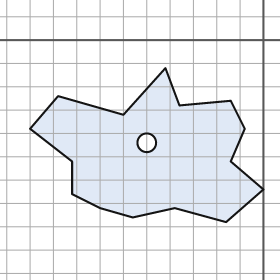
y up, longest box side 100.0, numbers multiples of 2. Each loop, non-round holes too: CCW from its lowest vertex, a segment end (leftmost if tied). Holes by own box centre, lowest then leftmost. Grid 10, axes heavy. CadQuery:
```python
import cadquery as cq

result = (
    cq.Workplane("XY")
    .moveTo(-16.0, -78.0)
    .lineTo(0.0, -64.0)
    .lineTo(-14.0, -52.0)
    .lineTo(-8.0, -38.0)
    .lineTo(-14.0, -26.0)
    .lineTo(-36.0, -28.0)
    .lineTo(-42.0, -12.0)
    .lineTo(-60.0, -32.0)
    .lineTo(-88.0, -24.0)
    .lineTo(-100.0, -38.0)
    .lineTo(-82.0, -52.0)
    .lineTo(-82.0, -66.0)
    .lineTo(-70.0, -72.0)
    .lineTo(-56.0, -76.0)
    .lineTo(-38.0, -72.0)
    .close()
    .moveTo(-50.0, -44.0)
    .circle(4.0)
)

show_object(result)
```